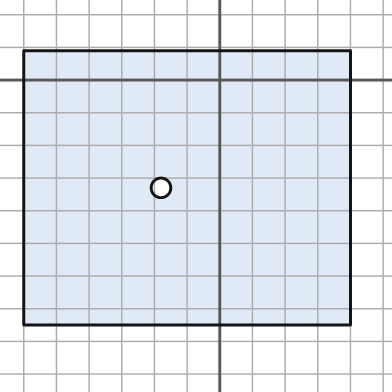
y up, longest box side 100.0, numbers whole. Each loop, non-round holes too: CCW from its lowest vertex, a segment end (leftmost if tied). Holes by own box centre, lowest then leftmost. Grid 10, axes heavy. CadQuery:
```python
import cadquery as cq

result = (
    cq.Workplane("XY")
    .moveTo(-60.0, -75.0)
    .lineTo(40.0, -75.0)
    .lineTo(40.0, 9.0)
    .lineTo(-60.0, 9.0)
    .close()
    .moveTo(-18.0, -33.0)
    .circle(3.0)
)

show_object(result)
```